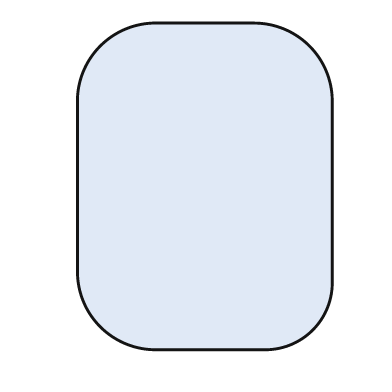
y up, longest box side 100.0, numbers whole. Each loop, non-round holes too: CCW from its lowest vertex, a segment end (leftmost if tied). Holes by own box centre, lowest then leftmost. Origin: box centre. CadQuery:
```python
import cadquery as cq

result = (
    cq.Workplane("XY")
    .moveTo(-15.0, -50.0)
    .lineTo(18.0, -50.0)
    .threePointArc((33.0, -44.0), (39.0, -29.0))
    .lineTo(39.0, 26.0)
    .threePointArc((32.0, 43.0), (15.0, 50.0))
    .lineTo(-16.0, 50.0)
    .threePointArc((-32.0, 43.0), (-39.0, 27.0))
    .lineTo(-39.0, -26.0)
    .threePointArc((-32.0, -43.0), (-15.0, -50.0))
    .close()
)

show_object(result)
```